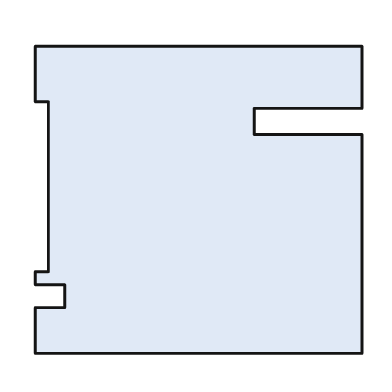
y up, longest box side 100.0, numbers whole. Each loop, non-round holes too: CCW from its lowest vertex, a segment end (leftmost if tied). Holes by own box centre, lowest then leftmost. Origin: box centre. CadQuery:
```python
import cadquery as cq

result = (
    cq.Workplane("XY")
    .moveTo(-50.0, -47.0)
    .lineTo(50.0, -47.0)
    .lineTo(50.0, 20.0)
    .lineTo(17.0, 20.0)
    .lineTo(17.0, 28.0)
    .lineTo(50.0, 28.0)
    .lineTo(50.0, 47.0)
    .lineTo(-50.0, 47.0)
    .lineTo(-50.0, 30.0)
    .lineTo(-46.0, 30.0)
    .lineTo(-46.0, -22.0)
    .lineTo(-50.0, -22.0)
    .lineTo(-50.0, -26.0)
    .lineTo(-41.0, -26.0)
    .lineTo(-41.0, -33.0)
    .lineTo(-50.0, -33.0)
    .close()
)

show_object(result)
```